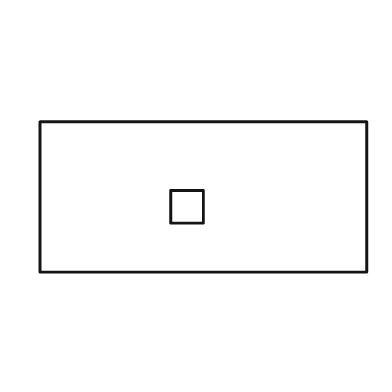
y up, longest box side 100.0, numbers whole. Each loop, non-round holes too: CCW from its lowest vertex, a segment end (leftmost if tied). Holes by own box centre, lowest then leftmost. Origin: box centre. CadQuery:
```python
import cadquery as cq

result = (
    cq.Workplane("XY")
    .moveTo(-50.0, -23.0)
    .lineTo(50.0, -23.0)
    .lineTo(50.0, 23.0)
    .lineTo(-50.0, 23.0)
    .close()
    .moveTo(-10.0, -8.0)
    .lineTo(0.0, -8.0)
    .lineTo(0.0, 2.0)
    .lineTo(-10.0, 2.0)
    .close()
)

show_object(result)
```